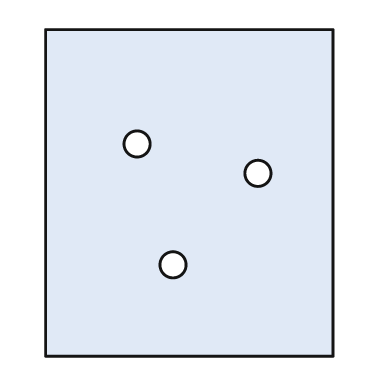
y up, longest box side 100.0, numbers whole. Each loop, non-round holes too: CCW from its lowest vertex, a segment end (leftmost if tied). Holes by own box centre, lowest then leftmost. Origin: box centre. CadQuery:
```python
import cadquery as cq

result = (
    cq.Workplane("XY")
    .moveTo(-44.0, -50.0)
    .lineTo(44.0, -50.0)
    .lineTo(44.0, 50.0)
    .lineTo(-44.0, 50.0)
    .close()
    .moveTo(-5.0, -22.0)
    .circle(4.0)
    .moveTo(21.0, 6.0)
    .circle(4.0)
    .moveTo(-16.0, 15.0)
    .circle(4.0)
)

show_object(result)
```